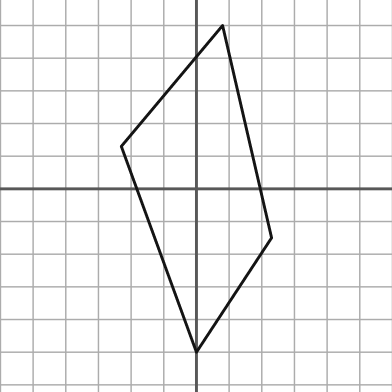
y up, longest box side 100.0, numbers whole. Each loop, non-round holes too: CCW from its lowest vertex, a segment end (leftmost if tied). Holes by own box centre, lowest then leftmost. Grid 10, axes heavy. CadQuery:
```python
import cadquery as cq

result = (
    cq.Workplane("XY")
    .moveTo(0.0, -50.0)
    .lineTo(23.0, -15.0)
    .lineTo(8.0, 50.0)
    .lineTo(-23.0, 13.0)
    .close()
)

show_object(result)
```